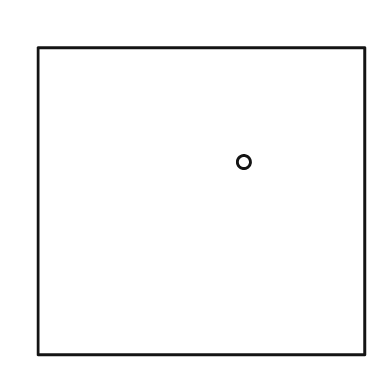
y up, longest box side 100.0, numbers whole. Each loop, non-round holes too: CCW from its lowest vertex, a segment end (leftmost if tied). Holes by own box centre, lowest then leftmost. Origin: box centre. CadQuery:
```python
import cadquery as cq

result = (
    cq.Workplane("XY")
    .moveTo(-50.0, -47.0)
    .lineTo(50.0, -47.0)
    .lineTo(50.0, 47.0)
    .lineTo(-50.0, 47.0)
    .close()
    .moveTo(13.0, 12.0)
    .circle(2.0)
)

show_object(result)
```